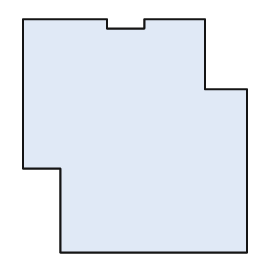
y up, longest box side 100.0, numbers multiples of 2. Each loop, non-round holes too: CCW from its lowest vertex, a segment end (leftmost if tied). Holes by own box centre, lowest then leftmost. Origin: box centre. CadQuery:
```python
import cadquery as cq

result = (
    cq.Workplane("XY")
    .moveTo(-32.0, -50.0)
    .lineTo(48.0, -50.0)
    .lineTo(48.0, 20.0)
    .lineTo(30.0, 20.0)
    .lineTo(30.0, 50.0)
    .lineTo(4.0, 50.0)
    .lineTo(4.0, 46.0)
    .lineTo(-12.0, 46.0)
    .lineTo(-12.0, 50.0)
    .lineTo(-48.0, 50.0)
    .lineTo(-48.0, -14.0)
    .lineTo(-32.0, -14.0)
    .close()
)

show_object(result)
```